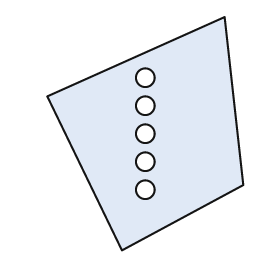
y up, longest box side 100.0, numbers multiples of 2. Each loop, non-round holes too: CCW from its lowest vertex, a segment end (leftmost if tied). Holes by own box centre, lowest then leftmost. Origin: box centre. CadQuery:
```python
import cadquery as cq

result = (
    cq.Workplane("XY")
    .moveTo(-10.0, -50.0)
    .lineTo(42.0, -22.0)
    .lineTo(34.0, 50.0)
    .lineTo(-42.0, 16.0)
    .close()
    .moveTo(0.0, -24.0)
    .circle(4.0)
    .moveTo(0.0, -12.0)
    .circle(4.0)
    .moveTo(0.0, 0.0)
    .circle(4.0)
    .moveTo(0.0, 12.0)
    .circle(4.0)
    .moveTo(0.0, 24.0)
    .circle(4.0)
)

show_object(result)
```